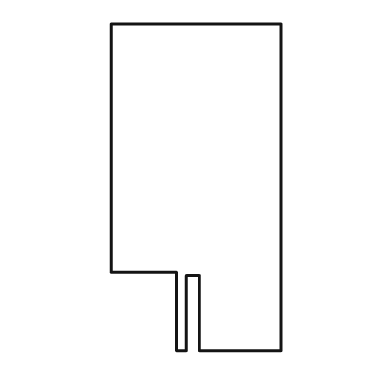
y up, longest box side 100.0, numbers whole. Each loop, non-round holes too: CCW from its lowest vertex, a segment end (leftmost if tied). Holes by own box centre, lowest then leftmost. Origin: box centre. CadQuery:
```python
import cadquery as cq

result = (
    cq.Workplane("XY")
    .moveTo(-6.0, -50.0)
    .lineTo(-3.0, -50.0)
    .lineTo(-3.0, -27.0)
    .lineTo(1.0, -27.0)
    .lineTo(1.0, -50.0)
    .lineTo(26.0, -50.0)
    .lineTo(26.0, 50.0)
    .lineTo(-26.0, 50.0)
    .lineTo(-26.0, -26.0)
    .lineTo(-6.0, -26.0)
    .close()
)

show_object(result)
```